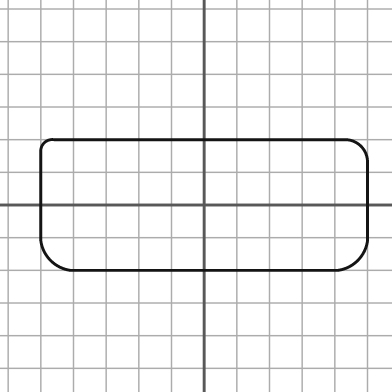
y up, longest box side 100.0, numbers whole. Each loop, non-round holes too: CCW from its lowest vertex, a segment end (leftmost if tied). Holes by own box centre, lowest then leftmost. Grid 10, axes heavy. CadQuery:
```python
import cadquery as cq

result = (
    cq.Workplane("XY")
    .moveTo(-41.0, -20.0)
    .lineTo(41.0, -20.0)
    .threePointArc((47.0, -17.0), (50.0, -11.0))
    .lineTo(50.0, 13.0)
    .threePointArc((48.0, 18.0), (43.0, 20.0))
    .lineTo(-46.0, 20.0)
    .threePointArc((-49.0, 19.0), (-50.0, 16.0))
    .lineTo(-50.0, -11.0)
    .threePointArc((-47.0, -17.0), (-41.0, -20.0))
    .close()
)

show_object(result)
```